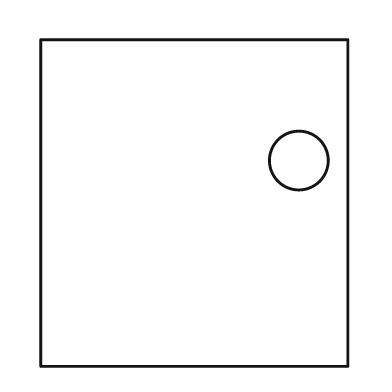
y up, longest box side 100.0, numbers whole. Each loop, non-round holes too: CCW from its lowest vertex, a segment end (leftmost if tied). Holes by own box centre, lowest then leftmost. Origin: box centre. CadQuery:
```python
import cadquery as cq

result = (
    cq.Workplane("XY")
    .moveTo(-47.0, -50.0)
    .lineTo(47.0, -50.0)
    .lineTo(47.0, 50.0)
    .lineTo(-47.0, 50.0)
    .close()
    .moveTo(32.0, 13.0)
    .circle(9.0)
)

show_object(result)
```